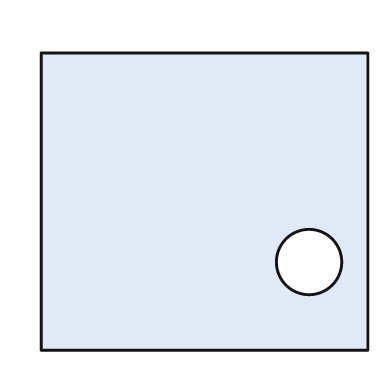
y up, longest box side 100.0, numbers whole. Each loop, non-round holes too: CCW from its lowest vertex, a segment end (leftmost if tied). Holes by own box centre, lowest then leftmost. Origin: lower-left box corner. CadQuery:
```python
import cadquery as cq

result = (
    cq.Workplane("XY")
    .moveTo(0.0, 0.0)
    .lineTo(100.0, 0.0)
    .lineTo(100.0, 91.0)
    .lineTo(0.0, 91.0)
    .close()
    .moveTo(82.0, 27.0)
    .circle(10.0)
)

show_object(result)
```